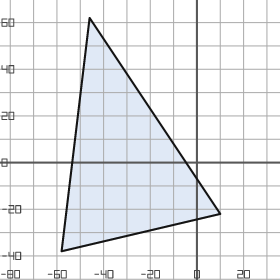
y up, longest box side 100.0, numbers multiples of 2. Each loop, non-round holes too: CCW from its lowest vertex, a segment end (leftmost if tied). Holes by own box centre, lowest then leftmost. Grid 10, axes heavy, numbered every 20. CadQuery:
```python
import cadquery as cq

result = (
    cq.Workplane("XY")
    .moveTo(-58.0, -38.0)
    .lineTo(10.0, -22.0)
    .lineTo(-46.0, 62.0)
    .close()
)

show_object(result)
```